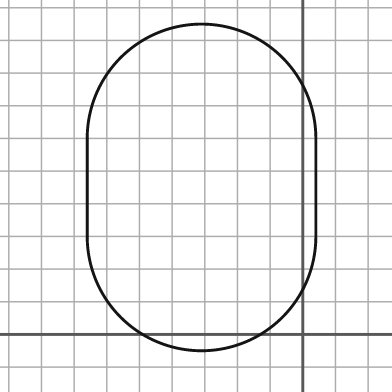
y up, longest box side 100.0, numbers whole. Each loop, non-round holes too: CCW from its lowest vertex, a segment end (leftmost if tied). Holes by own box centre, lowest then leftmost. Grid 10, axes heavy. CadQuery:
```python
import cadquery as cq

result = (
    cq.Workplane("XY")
    .moveTo(-66.0, 30.0)
    .threePointArc((-31.0, -5.0), (4.0, 30.0))
    .lineTo(4.0, 60.0)
    .threePointArc((-31.0, 95.0), (-66.0, 60.0))
    .close()
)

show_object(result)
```